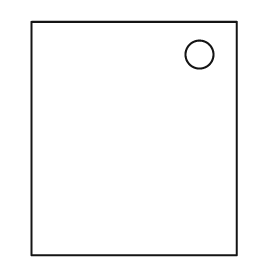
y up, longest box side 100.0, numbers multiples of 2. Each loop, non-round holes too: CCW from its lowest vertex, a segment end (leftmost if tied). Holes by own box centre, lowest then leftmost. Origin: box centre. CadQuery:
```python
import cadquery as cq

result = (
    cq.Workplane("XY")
    .moveTo(-44.0, -50.0)
    .lineTo(44.0, -50.0)
    .lineTo(44.0, 50.0)
    .lineTo(-44.0, 50.0)
    .close()
    .moveTo(28.0, 36.0)
    .circle(6.0)
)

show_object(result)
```